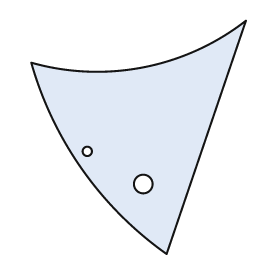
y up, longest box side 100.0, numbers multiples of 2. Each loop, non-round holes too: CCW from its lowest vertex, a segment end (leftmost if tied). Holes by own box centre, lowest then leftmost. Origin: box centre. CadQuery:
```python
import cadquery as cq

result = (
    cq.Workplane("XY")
    .moveTo(12.0, -50.0)
    .lineTo(46.0, 50.0)
    .threePointArc((2.0, 30.0), (-46.0, 32.0))
    .threePointArc((-24.0, -14.0), (12.0, -50.0))
    .close()
    .moveTo(2.0, -20.0)
    .circle(4.0)
    .moveTo(-22.0, -6.0)
    .circle(2.0)
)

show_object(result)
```